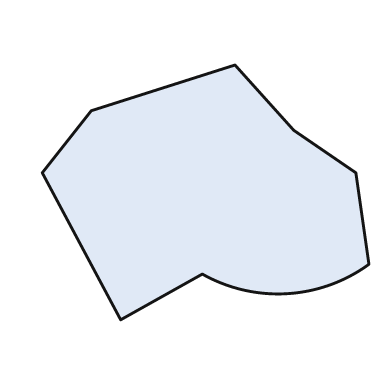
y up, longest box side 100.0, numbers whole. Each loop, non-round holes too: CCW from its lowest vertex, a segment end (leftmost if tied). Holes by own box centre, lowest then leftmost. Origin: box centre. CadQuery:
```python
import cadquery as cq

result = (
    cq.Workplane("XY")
    .moveTo(-26.0, -39.0)
    .lineTo(-1.0, -25.0)
    .threePointArc((25.0, -31.0), (50.0, -22.0))
    .lineTo(46.0, 6.0)
    .lineTo(27.0, 19.0)
    .lineTo(9.0, 39.0)
    .lineTo(-35.0, 25.0)
    .lineTo(-50.0, 6.0)
    .close()
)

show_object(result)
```